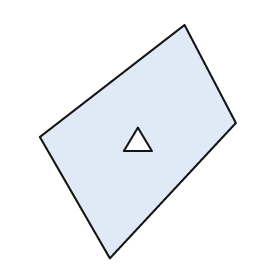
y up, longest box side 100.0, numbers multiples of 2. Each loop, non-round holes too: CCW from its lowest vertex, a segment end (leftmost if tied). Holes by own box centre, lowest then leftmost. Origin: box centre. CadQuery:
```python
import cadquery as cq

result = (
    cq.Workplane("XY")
    .moveTo(-12.0, -50.0)
    .lineTo(42.0, 8.0)
    .lineTo(20.0, 50.0)
    .lineTo(-42.0, 2.0)
    .close()
    .moveTo(-6.0, -4.0)
    .lineTo(6.0, -4.0)
    .lineTo(0.0, 6.0)
    .close()
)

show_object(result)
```